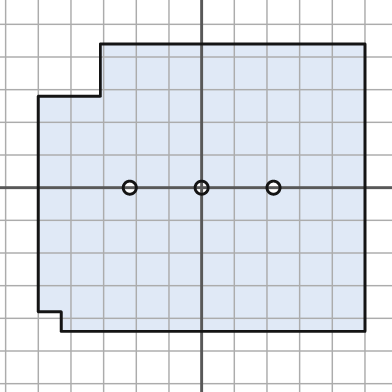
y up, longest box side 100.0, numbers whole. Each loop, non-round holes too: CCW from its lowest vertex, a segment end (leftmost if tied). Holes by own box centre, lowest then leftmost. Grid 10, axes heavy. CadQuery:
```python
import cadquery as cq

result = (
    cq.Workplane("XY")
    .moveTo(-43.0, -44.0)
    .lineTo(50.0, -44.0)
    .lineTo(50.0, 44.0)
    .lineTo(-31.0, 44.0)
    .lineTo(-31.0, 28.0)
    .lineTo(-50.0, 28.0)
    .lineTo(-50.0, -38.0)
    .lineTo(-43.0, -38.0)
    .close()
    .moveTo(-22.0, 0.0)
    .circle(2.0)
    .moveTo(0.0, 0.0)
    .circle(2.0)
    .moveTo(22.0, 0.0)
    .circle(2.0)
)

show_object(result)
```